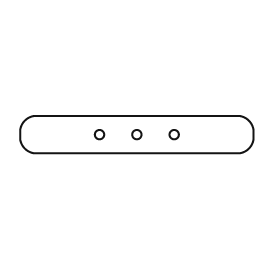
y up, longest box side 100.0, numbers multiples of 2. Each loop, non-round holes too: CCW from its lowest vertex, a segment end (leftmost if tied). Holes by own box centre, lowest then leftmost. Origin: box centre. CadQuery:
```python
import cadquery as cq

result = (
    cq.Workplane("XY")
    .moveTo(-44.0, -8.0)
    .lineTo(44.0, -8.0)
    .threePointArc((48.0, -6.0), (50.0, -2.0))
    .lineTo(50.0, 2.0)
    .threePointArc((48.0, 6.0), (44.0, 8.0))
    .lineTo(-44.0, 8.0)
    .threePointArc((-48.0, 6.0), (-50.0, 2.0))
    .lineTo(-50.0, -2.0)
    .threePointArc((-48.0, -6.0), (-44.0, -8.0))
    .close()
    .moveTo(-16.0, 0.0)
    .circle(2.0)
    .moveTo(0.0, 0.0)
    .circle(2.0)
    .moveTo(16.0, 0.0)
    .circle(2.0)
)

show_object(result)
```